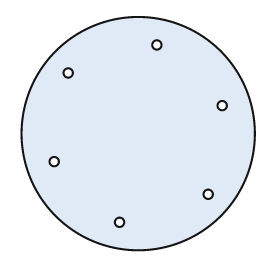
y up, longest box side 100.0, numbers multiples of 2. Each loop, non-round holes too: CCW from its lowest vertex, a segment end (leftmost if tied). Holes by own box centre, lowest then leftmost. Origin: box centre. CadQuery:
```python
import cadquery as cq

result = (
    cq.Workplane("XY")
    .moveTo(0.0, 0.0)
    .circle(50.0)
    .moveTo(-8.0, -38.0)
    .circle(2.0)
    .moveTo(30.0, -26.0)
    .circle(2.0)
    .moveTo(-36.0, -12.0)
    .circle(2.0)
    .moveTo(36.0, 12.0)
    .circle(2.0)
    .moveTo(-30.0, 26.0)
    .circle(2.0)
    .moveTo(8.0, 38.0)
    .circle(2.0)
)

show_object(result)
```